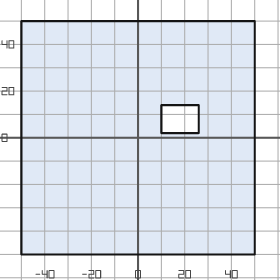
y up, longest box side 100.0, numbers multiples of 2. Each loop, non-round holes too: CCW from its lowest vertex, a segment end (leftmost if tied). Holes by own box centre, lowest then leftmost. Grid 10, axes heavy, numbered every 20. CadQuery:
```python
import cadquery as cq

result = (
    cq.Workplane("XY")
    .moveTo(-50.0, -50.0)
    .lineTo(50.0, -50.0)
    .lineTo(50.0, 50.0)
    .lineTo(-50.0, 50.0)
    .close()
    .moveTo(10.0, 2.0)
    .lineTo(26.0, 2.0)
    .lineTo(26.0, 14.0)
    .lineTo(10.0, 14.0)
    .close()
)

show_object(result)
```